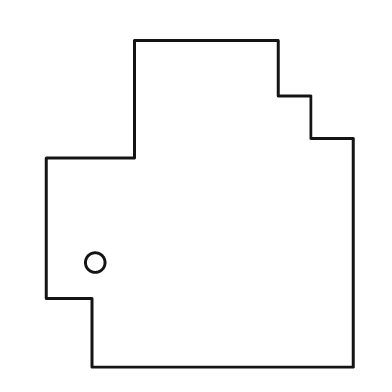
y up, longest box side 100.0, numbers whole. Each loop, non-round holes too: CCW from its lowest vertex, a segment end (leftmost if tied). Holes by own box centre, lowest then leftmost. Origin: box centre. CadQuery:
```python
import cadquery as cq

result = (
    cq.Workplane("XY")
    .moveTo(-33.0, -50.0)
    .lineTo(47.0, -50.0)
    .lineTo(47.0, 20.0)
    .lineTo(34.0, 20.0)
    .lineTo(34.0, 33.0)
    .lineTo(24.0, 33.0)
    .lineTo(24.0, 50.0)
    .lineTo(-20.0, 50.0)
    .lineTo(-20.0, 14.0)
    .lineTo(-47.0, 14.0)
    .lineTo(-47.0, -29.0)
    .lineTo(-33.0, -29.0)
    .close()
    .moveTo(-32.0, -18.0)
    .circle(3.0)
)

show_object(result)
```